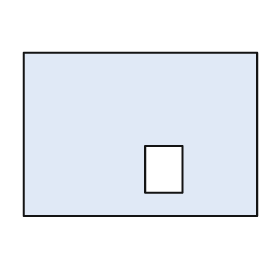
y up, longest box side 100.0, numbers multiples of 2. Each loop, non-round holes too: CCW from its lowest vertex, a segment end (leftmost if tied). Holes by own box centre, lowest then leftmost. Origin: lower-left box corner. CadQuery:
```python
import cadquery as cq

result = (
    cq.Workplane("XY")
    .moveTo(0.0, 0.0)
    .lineTo(100.0, 0.0)
    .lineTo(100.0, 70.0)
    .lineTo(0.0, 70.0)
    .close()
    .moveTo(52.0, 10.0)
    .lineTo(68.0, 10.0)
    .lineTo(68.0, 30.0)
    .lineTo(52.0, 30.0)
    .close()
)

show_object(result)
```